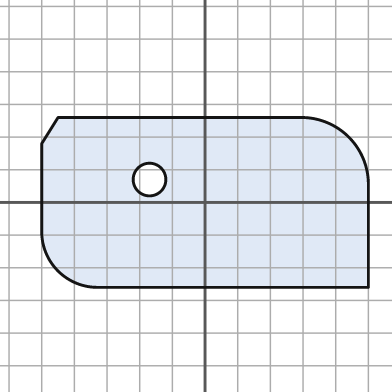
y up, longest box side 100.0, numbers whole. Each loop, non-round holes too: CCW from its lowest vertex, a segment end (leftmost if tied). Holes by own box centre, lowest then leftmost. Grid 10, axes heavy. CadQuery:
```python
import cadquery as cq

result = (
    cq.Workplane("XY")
    .moveTo(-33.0, -26.0)
    .lineTo(50.0, -26.0)
    .lineTo(50.0, 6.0)
    .threePointArc((44.0, 20.0), (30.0, 26.0))
    .lineTo(-45.0, 26.0)
    .lineTo(-50.0, 18.0)
    .lineTo(-50.0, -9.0)
    .threePointArc((-45.0, -21.0), (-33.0, -26.0))
    .close()
    .moveTo(-17.0, 7.0)
    .circle(5.0)
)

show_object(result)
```